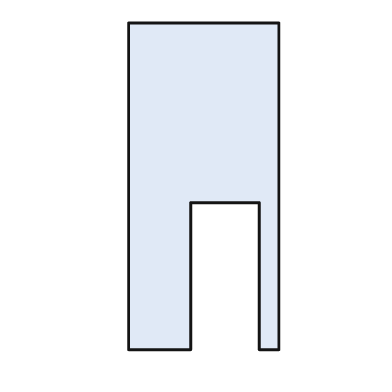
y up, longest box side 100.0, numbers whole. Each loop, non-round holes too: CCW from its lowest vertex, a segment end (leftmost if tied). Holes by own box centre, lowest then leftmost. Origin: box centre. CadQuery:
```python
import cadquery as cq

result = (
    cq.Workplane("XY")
    .moveTo(-23.0, -50.0)
    .lineTo(-4.0, -50.0)
    .lineTo(-4.0, -5.0)
    .lineTo(17.0, -5.0)
    .lineTo(17.0, -50.0)
    .lineTo(23.0, -50.0)
    .lineTo(23.0, 50.0)
    .lineTo(-23.0, 50.0)
    .close()
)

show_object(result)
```